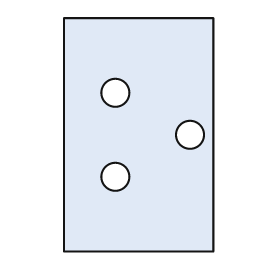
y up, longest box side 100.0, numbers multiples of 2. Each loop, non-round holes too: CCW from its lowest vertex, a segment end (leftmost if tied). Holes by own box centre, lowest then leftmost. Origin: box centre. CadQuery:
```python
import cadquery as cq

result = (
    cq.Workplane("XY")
    .moveTo(-32.0, -50.0)
    .lineTo(32.0, -50.0)
    .lineTo(32.0, 50.0)
    .lineTo(-32.0, 50.0)
    .close()
    .moveTo(-10.0, -18.0)
    .circle(6.0)
    .moveTo(22.0, 0.0)
    .circle(6.0)
    .moveTo(-10.0, 18.0)
    .circle(6.0)
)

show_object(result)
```